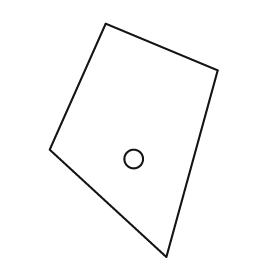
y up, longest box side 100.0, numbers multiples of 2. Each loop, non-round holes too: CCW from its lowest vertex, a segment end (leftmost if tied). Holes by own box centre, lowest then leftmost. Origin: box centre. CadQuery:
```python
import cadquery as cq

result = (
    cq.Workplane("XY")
    .moveTo(14.0, -50.0)
    .lineTo(36.0, 30.0)
    .lineTo(-12.0, 50.0)
    .lineTo(-36.0, -4.0)
    .close()
    .moveTo(0.0, -8.0)
    .circle(4.0)
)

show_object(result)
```